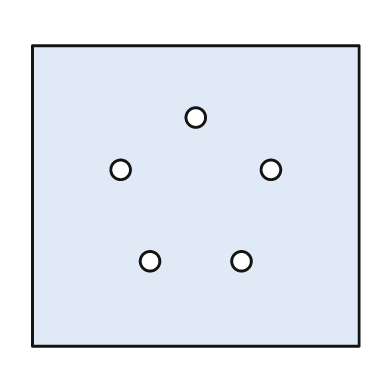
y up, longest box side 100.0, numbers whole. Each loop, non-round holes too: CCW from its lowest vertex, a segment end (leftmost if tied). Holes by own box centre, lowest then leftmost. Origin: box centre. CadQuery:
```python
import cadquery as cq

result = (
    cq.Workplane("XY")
    .moveTo(-50.0, -46.0)
    .lineTo(50.0, -46.0)
    .lineTo(50.0, 46.0)
    .lineTo(-50.0, 46.0)
    .close()
    .moveTo(-14.0, -20.0)
    .circle(3.0)
    .moveTo(14.0, -20.0)
    .circle(3.0)
    .moveTo(-23.0, 8.0)
    .circle(3.0)
    .moveTo(23.0, 8.0)
    .circle(3.0)
    .moveTo(0.0, 24.0)
    .circle(3.0)
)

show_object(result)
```